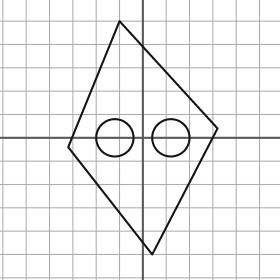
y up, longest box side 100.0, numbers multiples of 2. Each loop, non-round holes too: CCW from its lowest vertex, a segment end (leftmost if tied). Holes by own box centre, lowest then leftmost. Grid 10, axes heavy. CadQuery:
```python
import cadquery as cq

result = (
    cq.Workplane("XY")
    .moveTo(4.0, -50.0)
    .lineTo(32.0, 4.0)
    .lineTo(-10.0, 50.0)
    .lineTo(-32.0, -4.0)
    .close()
    .moveTo(-12.0, 0.0)
    .circle(8.0)
    .moveTo(12.0, 0.0)
    .circle(8.0)
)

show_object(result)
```